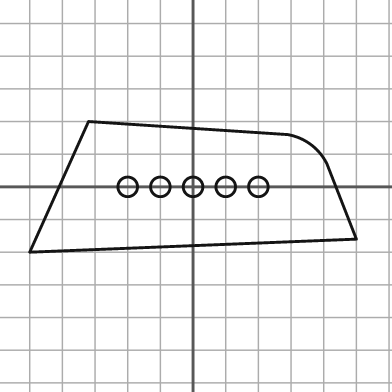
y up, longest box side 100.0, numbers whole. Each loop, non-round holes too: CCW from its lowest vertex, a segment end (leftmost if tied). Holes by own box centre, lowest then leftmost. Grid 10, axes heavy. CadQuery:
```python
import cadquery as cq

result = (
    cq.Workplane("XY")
    .moveTo(-50.0, -20.0)
    .lineTo(50.0, -16.0)
    .lineTo(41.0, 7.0)
    .threePointArc((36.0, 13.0), (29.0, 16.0))
    .lineTo(-32.0, 20.0)
    .close()
    .moveTo(-20.0, 0.0)
    .circle(3.0)
    .moveTo(-10.0, 0.0)
    .circle(3.0)
    .moveTo(0.0, 0.0)
    .circle(3.0)
    .moveTo(10.0, 0.0)
    .circle(3.0)
    .moveTo(20.0, 0.0)
    .circle(3.0)
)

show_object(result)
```